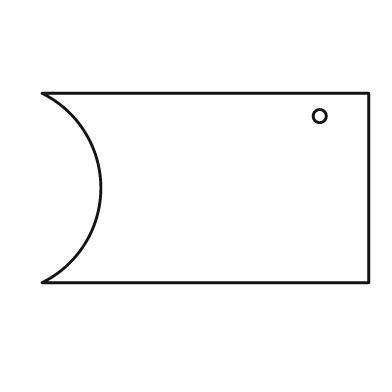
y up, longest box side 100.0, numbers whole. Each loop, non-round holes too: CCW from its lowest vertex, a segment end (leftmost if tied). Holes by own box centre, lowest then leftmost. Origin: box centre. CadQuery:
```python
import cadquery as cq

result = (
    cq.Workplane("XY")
    .moveTo(-50.0, -29.0)
    .lineTo(50.0, -29.0)
    .lineTo(50.0, 29.0)
    .lineTo(-50.0, 29.0)
    .threePointArc((-32.0, 0.0), (-50.0, -29.0))
    .close()
    .moveTo(35.0, 22.0)
    .circle(2.0)
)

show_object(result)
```